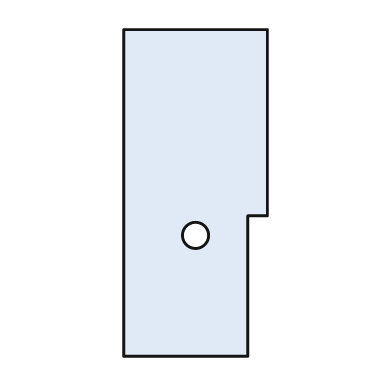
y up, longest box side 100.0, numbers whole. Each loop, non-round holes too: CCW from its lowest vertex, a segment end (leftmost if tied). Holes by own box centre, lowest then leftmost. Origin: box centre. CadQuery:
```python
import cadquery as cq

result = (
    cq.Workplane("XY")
    .moveTo(-22.0, -50.0)
    .lineTo(16.0, -50.0)
    .lineTo(16.0, -7.0)
    .lineTo(22.0, -7.0)
    .lineTo(22.0, 50.0)
    .lineTo(-22.0, 50.0)
    .close()
    .moveTo(0.0, -13.0)
    .circle(4.0)
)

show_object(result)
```